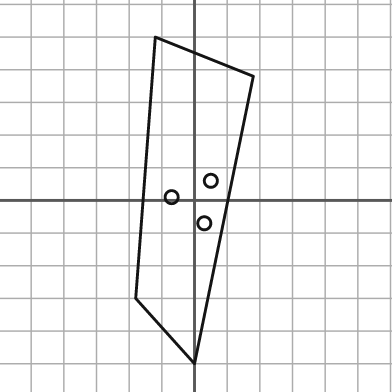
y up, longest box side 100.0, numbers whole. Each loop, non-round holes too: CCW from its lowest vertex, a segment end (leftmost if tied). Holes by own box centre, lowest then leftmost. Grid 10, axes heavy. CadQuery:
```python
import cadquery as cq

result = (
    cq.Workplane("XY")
    .moveTo(0.0, -50.0)
    .lineTo(18.0, 38.0)
    .lineTo(-12.0, 50.0)
    .lineTo(-18.0, -30.0)
    .close()
    .moveTo(3.0, -7.0)
    .circle(2.0)
    .moveTo(-7.0, 1.0)
    .circle(2.0)
    .moveTo(5.0, 6.0)
    .circle(2.0)
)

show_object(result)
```